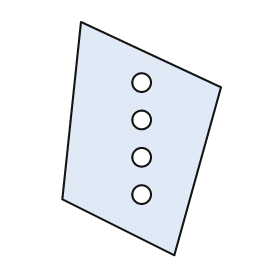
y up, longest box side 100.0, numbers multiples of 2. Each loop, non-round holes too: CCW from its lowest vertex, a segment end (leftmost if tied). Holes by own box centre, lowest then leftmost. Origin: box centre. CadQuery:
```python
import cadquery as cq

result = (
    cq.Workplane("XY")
    .moveTo(14.0, -50.0)
    .lineTo(34.0, 22.0)
    .lineTo(-26.0, 50.0)
    .lineTo(-34.0, -26.0)
    .close()
    .moveTo(0.0, -24.0)
    .circle(4.0)
    .moveTo(0.0, -8.0)
    .circle(4.0)
    .moveTo(0.0, 8.0)
    .circle(4.0)
    .moveTo(0.0, 24.0)
    .circle(4.0)
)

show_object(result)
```